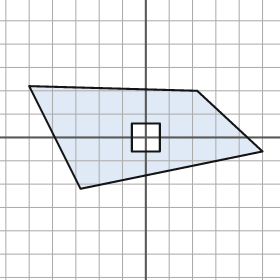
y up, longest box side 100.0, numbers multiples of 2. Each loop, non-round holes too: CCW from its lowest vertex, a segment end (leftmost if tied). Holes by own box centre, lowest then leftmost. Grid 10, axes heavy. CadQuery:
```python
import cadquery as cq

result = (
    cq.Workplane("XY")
    .moveTo(-28.0, -22.0)
    .lineTo(50.0, -6.0)
    .lineTo(22.0, 20.0)
    .lineTo(-50.0, 22.0)
    .close()
    .moveTo(-6.0, -6.0)
    .lineTo(6.0, -6.0)
    .lineTo(6.0, 6.0)
    .lineTo(-6.0, 6.0)
    .close()
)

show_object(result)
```